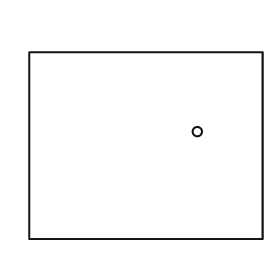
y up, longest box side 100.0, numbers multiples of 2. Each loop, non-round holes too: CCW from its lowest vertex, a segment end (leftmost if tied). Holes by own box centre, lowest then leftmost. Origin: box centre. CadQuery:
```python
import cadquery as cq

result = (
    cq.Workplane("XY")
    .moveTo(-50.0, -40.0)
    .lineTo(50.0, -40.0)
    .lineTo(50.0, 40.0)
    .lineTo(-50.0, 40.0)
    .close()
    .moveTo(22.0, 6.0)
    .circle(2.0)
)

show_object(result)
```